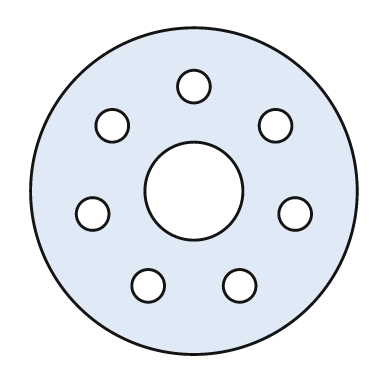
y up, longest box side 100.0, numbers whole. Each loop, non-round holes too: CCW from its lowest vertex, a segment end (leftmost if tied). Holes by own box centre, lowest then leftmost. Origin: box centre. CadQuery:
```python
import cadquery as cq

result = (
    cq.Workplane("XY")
    .moveTo(0.0, 0.0)
    .circle(50.0)
    .moveTo(-14.0, -29.0)
    .circle(5.0)
    .moveTo(14.0, -29.0)
    .circle(5.0)
    .moveTo(-31.0, -7.0)
    .circle(5.0)
    .moveTo(31.0, -7.0)
    .circle(5.0)
    .moveTo(0.0, 0.0)
    .circle(15.0)
    .moveTo(-25.0, 20.0)
    .circle(5.0)
    .moveTo(25.0, 20.0)
    .circle(5.0)
    .moveTo(0.0, 32.0)
    .circle(5.0)
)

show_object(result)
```